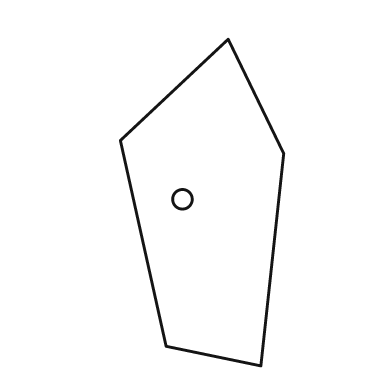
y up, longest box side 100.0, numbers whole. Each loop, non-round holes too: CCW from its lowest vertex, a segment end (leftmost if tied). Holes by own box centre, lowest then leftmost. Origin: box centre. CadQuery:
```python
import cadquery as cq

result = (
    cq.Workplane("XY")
    .moveTo(18.0, -50.0)
    .lineTo(25.0, 15.0)
    .lineTo(8.0, 50.0)
    .lineTo(-25.0, 19.0)
    .lineTo(-11.0, -44.0)
    .close()
    .moveTo(-6.0, 1.0)
    .circle(3.0)
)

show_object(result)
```